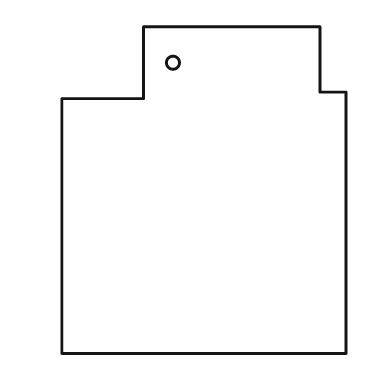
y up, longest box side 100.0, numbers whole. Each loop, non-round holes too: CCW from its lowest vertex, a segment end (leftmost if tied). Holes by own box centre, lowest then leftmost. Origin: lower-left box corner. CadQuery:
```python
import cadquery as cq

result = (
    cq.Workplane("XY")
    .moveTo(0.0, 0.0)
    .lineTo(87.0, 0.0)
    .lineTo(87.0, 80.0)
    .lineTo(79.0, 80.0)
    .lineTo(79.0, 100.0)
    .lineTo(25.0, 100.0)
    .lineTo(25.0, 78.0)
    .lineTo(0.0, 78.0)
    .close()
    .moveTo(34.0, 89.0)
    .circle(2.0)
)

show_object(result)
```